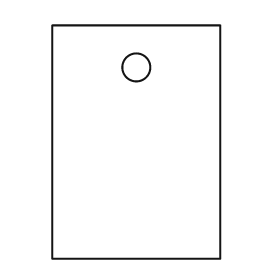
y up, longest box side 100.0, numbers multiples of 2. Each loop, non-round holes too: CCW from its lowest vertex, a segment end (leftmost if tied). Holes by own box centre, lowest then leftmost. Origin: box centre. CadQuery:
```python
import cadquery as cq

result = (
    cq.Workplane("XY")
    .moveTo(-36.0, -50.0)
    .lineTo(36.0, -50.0)
    .lineTo(36.0, 50.0)
    .lineTo(-36.0, 50.0)
    .close()
    .moveTo(0.0, 32.0)
    .circle(6.0)
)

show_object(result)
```